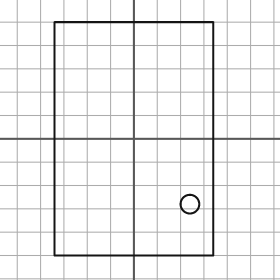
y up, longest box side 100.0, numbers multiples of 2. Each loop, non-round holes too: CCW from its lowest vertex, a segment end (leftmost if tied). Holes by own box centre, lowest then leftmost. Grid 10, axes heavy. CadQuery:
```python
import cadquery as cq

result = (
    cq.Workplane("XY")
    .moveTo(-34.0, -50.0)
    .lineTo(34.0, -50.0)
    .lineTo(34.0, 50.0)
    .lineTo(-34.0, 50.0)
    .close()
    .moveTo(24.0, -28.0)
    .circle(4.0)
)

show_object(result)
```